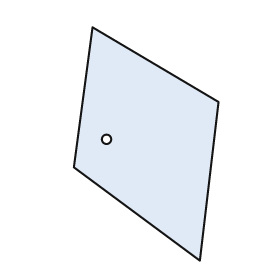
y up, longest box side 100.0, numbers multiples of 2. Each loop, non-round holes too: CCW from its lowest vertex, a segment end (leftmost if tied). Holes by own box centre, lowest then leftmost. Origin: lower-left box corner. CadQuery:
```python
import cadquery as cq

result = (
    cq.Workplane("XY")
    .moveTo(54.0, 0.0)
    .lineTo(62.0, 68.0)
    .lineTo(8.0, 100.0)
    .lineTo(0.0, 40.0)
    .close()
    .moveTo(14.0, 52.0)
    .circle(2.0)
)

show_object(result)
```